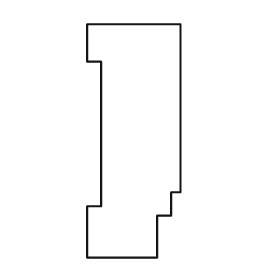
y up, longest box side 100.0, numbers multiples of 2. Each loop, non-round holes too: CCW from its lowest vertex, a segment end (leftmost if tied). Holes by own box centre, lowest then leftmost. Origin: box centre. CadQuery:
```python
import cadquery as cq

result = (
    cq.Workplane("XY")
    .moveTo(-20.0, -50.0)
    .lineTo(10.0, -50.0)
    .lineTo(10.0, -32.0)
    .lineTo(16.0, -32.0)
    .lineTo(16.0, -22.0)
    .lineTo(20.0, -22.0)
    .lineTo(20.0, 50.0)
    .lineTo(-20.0, 50.0)
    .lineTo(-20.0, 34.0)
    .lineTo(-14.0, 34.0)
    .lineTo(-14.0, -28.0)
    .lineTo(-20.0, -28.0)
    .close()
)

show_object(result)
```